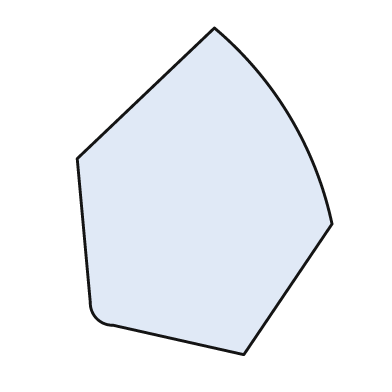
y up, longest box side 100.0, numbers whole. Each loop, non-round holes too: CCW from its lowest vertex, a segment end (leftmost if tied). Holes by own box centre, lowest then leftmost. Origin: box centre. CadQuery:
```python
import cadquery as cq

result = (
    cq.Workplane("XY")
    .moveTo(12.0, -50.0)
    .lineTo(39.0, -10.0)
    .threePointArc((26.0, 23.0), (3.0, 50.0))
    .lineTo(-39.0, 10.0)
    .lineTo(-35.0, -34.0)
    .threePointArc((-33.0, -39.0), (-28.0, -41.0))
    .close()
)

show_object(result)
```